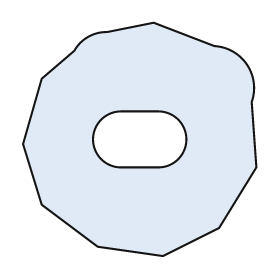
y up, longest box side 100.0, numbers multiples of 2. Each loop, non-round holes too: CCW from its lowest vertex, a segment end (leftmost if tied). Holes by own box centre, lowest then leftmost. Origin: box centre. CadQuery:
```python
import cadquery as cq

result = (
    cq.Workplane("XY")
    .moveTo(10.0, -50.0)
    .lineTo(34.0, -38.0)
    .lineTo(50.0, -12.0)
    .lineTo(48.0, 16.0)
    .threePointArc((46.0, 32.0), (32.0, 40.0))
    .lineTo(6.0, 50.0)
    .lineTo(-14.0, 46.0)
    .threePointArc((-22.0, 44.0), (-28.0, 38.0))
    .lineTo(-42.0, 26.0)
    .lineTo(-50.0, -2.0)
    .lineTo(-42.0, -28.0)
    .lineTo(-18.0, -46.0)
    .close()
    .moveTo(-8.0, -12.0)
    .lineTo(8.0, -12.0)
    .threePointArc((20.0, 0.0), (8.0, 12.0))
    .lineTo(-8.0, 12.0)
    .threePointArc((-20.0, 0.0), (-8.0, -12.0))
    .close()
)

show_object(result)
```